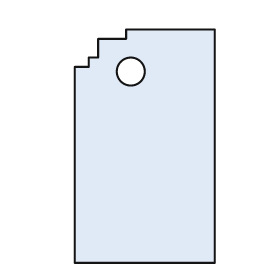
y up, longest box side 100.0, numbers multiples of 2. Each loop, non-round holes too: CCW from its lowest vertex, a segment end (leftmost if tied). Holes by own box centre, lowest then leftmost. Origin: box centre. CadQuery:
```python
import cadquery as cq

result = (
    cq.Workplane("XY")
    .moveTo(-30.0, -50.0)
    .lineTo(30.0, -50.0)
    .lineTo(30.0, 50.0)
    .lineTo(-8.0, 50.0)
    .lineTo(-8.0, 46.0)
    .lineTo(-20.0, 46.0)
    .lineTo(-20.0, 38.0)
    .lineTo(-24.0, 38.0)
    .lineTo(-24.0, 34.0)
    .lineTo(-30.0, 34.0)
    .close()
    .moveTo(-6.0, 32.0)
    .circle(6.0)
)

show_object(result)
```